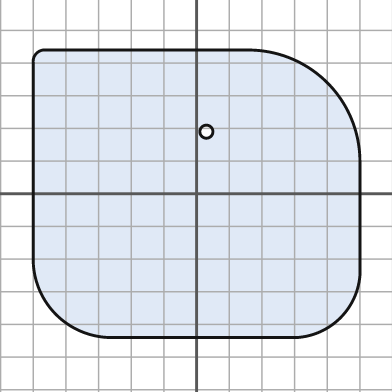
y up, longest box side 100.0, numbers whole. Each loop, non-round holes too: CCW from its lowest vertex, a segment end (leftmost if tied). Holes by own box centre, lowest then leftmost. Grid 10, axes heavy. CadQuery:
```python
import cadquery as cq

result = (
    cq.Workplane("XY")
    .moveTo(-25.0, -44.0)
    .lineTo(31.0, -44.0)
    .threePointArc((44.0, -38.0), (50.0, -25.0))
    .lineTo(50.0, 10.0)
    .threePointArc((40.0, 34.0), (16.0, 44.0))
    .lineTo(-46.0, 44.0)
    .threePointArc((-49.0, 43.0), (-50.0, 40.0))
    .lineTo(-50.0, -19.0)
    .threePointArc((-43.0, -37.0), (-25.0, -44.0))
    .close()
    .moveTo(3.0, 19.0)
    .circle(2.0)
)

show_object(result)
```